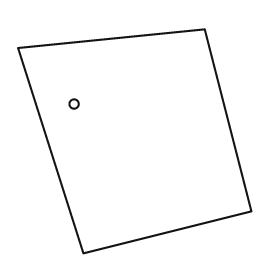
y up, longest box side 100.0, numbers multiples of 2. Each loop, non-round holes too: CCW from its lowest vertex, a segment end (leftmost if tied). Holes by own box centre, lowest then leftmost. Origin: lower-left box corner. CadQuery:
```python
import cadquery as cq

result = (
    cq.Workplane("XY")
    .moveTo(28.0, 0.0)
    .lineTo(100.0, 18.0)
    .lineTo(80.0, 96.0)
    .lineTo(0.0, 88.0)
    .close()
    .moveTo(24.0, 64.0)
    .circle(2.0)
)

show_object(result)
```